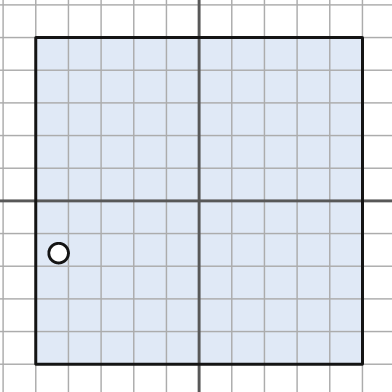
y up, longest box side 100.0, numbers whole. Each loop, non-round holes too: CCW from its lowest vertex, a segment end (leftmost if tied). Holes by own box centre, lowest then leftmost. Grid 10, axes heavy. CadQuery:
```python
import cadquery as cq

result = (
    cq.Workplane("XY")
    .moveTo(-50.0, -50.0)
    .lineTo(50.0, -50.0)
    .lineTo(50.0, 50.0)
    .lineTo(-50.0, 50.0)
    .close()
    .moveTo(-43.0, -16.0)
    .circle(3.0)
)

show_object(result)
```